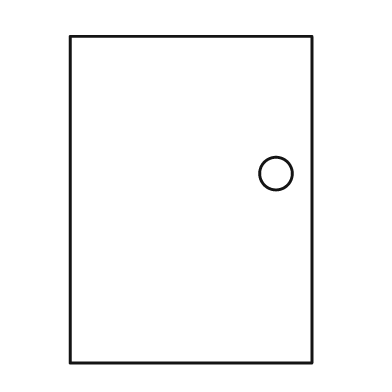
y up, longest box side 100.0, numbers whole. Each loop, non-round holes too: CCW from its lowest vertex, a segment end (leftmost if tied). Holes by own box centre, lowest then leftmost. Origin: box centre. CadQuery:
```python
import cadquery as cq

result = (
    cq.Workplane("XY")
    .moveTo(-37.0, -50.0)
    .lineTo(37.0, -50.0)
    .lineTo(37.0, 50.0)
    .lineTo(-37.0, 50.0)
    .close()
    .moveTo(26.0, 8.0)
    .circle(5.0)
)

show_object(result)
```